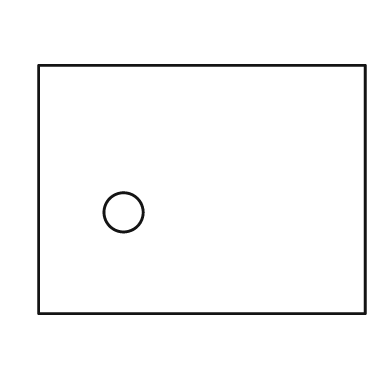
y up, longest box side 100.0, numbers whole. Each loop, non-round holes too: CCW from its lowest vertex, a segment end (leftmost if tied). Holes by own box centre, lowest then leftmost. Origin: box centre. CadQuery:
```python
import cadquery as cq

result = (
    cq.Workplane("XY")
    .moveTo(-50.0, -38.0)
    .lineTo(50.0, -38.0)
    .lineTo(50.0, 38.0)
    .lineTo(-50.0, 38.0)
    .close()
    .moveTo(-24.0, -7.0)
    .circle(6.0)
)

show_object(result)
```